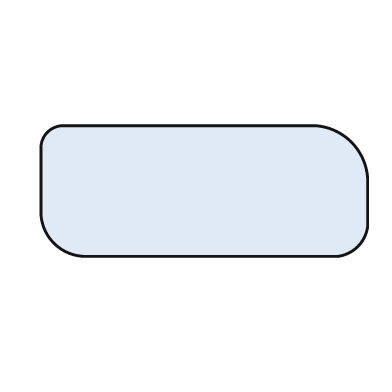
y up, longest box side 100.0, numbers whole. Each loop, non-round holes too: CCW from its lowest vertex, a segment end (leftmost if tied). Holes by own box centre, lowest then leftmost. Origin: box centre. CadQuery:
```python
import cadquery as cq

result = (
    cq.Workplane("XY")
    .moveTo(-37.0, -20.0)
    .lineTo(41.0, -20.0)
    .threePointArc((47.0, -17.0), (50.0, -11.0))
    .lineTo(50.0, 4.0)
    .threePointArc((45.0, 15.0), (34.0, 20.0))
    .lineTo(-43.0, 20.0)
    .threePointArc((-48.0, 18.0), (-50.0, 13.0))
    .lineTo(-50.0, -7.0)
    .threePointArc((-46.0, -16.0), (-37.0, -20.0))
    .close()
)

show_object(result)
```